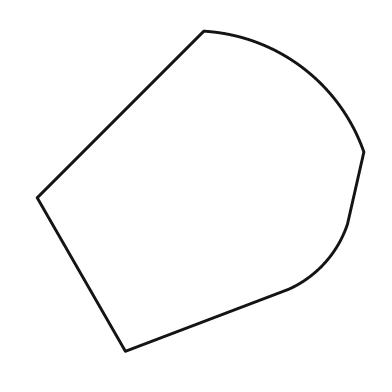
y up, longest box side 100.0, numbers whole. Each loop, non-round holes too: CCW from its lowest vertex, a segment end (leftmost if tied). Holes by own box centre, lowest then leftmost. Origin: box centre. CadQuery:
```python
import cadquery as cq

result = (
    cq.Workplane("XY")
    .moveTo(-23.0, -49.0)
    .lineTo(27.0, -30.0)
    .threePointArc((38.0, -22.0), (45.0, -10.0))
    .lineTo(50.0, 12.0)
    .threePointArc((31.0, 38.0), (1.0, 49.0))
    .lineTo(-50.0, -2.0)
    .close()
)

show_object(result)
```